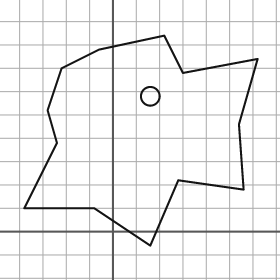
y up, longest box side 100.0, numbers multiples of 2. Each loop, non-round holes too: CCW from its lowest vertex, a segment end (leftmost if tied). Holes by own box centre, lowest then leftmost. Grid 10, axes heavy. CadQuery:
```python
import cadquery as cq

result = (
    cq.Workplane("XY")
    .moveTo(16.0, -6.0)
    .lineTo(28.0, 22.0)
    .lineTo(56.0, 18.0)
    .lineTo(54.0, 46.0)
    .lineTo(62.0, 74.0)
    .lineTo(30.0, 68.0)
    .lineTo(22.0, 84.0)
    .lineTo(-6.0, 78.0)
    .lineTo(-22.0, 70.0)
    .lineTo(-28.0, 52.0)
    .lineTo(-24.0, 38.0)
    .lineTo(-38.0, 10.0)
    .lineTo(-8.0, 10.0)
    .close()
    .moveTo(16.0, 58.0)
    .circle(4.0)
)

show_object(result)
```